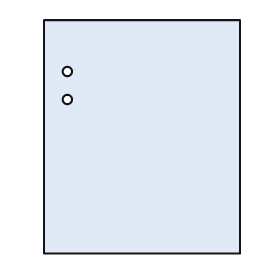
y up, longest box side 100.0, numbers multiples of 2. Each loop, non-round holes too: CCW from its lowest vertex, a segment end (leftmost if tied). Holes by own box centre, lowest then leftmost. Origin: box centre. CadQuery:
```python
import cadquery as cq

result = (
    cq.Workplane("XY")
    .moveTo(-42.0, -50.0)
    .lineTo(42.0, -50.0)
    .lineTo(42.0, 50.0)
    .lineTo(-42.0, 50.0)
    .close()
    .moveTo(-32.0, 16.0)
    .circle(2.0)
    .moveTo(-32.0, 28.0)
    .circle(2.0)
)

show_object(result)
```